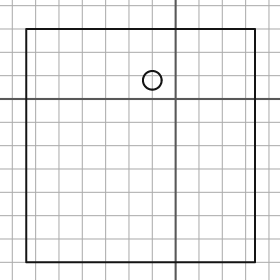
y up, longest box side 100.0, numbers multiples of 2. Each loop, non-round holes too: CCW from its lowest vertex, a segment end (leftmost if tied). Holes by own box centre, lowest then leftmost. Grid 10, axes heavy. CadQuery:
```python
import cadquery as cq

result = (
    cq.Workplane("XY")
    .moveTo(-64.0, -70.0)
    .lineTo(34.0, -70.0)
    .lineTo(34.0, 30.0)
    .lineTo(-64.0, 30.0)
    .close()
    .moveTo(-10.0, 8.0)
    .circle(4.0)
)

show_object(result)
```